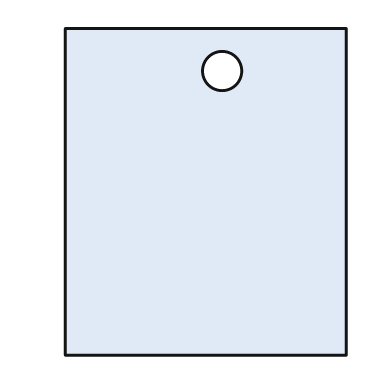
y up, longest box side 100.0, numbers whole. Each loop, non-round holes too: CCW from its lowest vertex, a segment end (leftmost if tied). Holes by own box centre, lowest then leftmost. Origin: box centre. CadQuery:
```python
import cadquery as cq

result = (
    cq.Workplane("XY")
    .moveTo(-43.0, -50.0)
    .lineTo(43.0, -50.0)
    .lineTo(43.0, 50.0)
    .lineTo(-43.0, 50.0)
    .close()
    .moveTo(5.0, 37.0)
    .circle(6.0)
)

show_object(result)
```